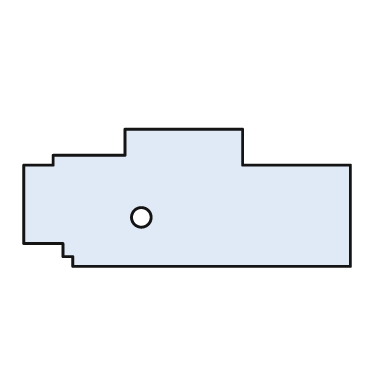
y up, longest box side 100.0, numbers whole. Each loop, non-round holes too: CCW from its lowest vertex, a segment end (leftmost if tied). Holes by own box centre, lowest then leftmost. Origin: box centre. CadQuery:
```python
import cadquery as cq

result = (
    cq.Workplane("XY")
    .moveTo(-35.0, -21.0)
    .lineTo(50.0, -21.0)
    .lineTo(50.0, 10.0)
    .lineTo(17.0, 10.0)
    .lineTo(17.0, 21.0)
    .lineTo(-19.0, 21.0)
    .lineTo(-19.0, 13.0)
    .lineTo(-41.0, 13.0)
    .lineTo(-41.0, 10.0)
    .lineTo(-50.0, 10.0)
    .lineTo(-50.0, -14.0)
    .lineTo(-38.0, -14.0)
    .lineTo(-38.0, -18.0)
    .lineTo(-35.0, -18.0)
    .close()
    .moveTo(-14.0, -6.0)
    .circle(3.0)
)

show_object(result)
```